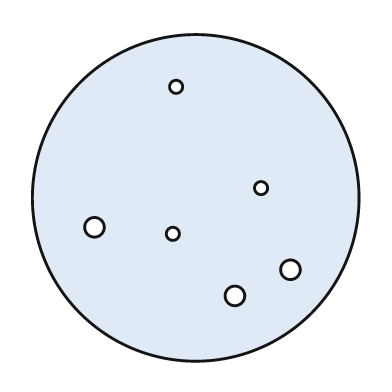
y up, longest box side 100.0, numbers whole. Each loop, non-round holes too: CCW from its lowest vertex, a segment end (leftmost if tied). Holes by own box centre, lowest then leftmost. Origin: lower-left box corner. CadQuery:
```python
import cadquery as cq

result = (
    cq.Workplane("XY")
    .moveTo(50.0, 50.0)
    .circle(50.0)
    .moveTo(62.0, 20.0)
    .circle(3.0)
    .moveTo(79.0, 28.0)
    .circle(3.0)
    .moveTo(43.0, 39.0)
    .circle(2.0)
    .moveTo(19.0, 41.0)
    .circle(3.0)
    .moveTo(70.0, 53.0)
    .circle(2.0)
    .moveTo(44.0, 84.0)
    .circle(2.0)
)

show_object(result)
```